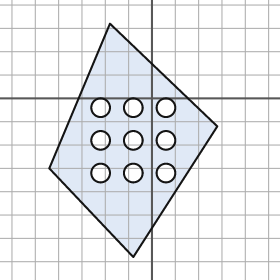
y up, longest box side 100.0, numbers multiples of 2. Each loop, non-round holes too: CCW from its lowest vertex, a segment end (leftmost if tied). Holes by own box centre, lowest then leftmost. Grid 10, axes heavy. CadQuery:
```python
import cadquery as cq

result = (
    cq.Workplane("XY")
    .moveTo(-8.0, -68.0)
    .lineTo(28.0, -12.0)
    .lineTo(-18.0, 32.0)
    .lineTo(-44.0, -30.0)
    .close()
    .moveTo(-22.0, -32.0)
    .circle(4.0)
    .moveTo(-8.0, -32.0)
    .circle(4.0)
    .moveTo(6.0, -32.0)
    .circle(4.0)
    .moveTo(-22.0, -18.0)
    .circle(4.0)
    .moveTo(-8.0, -18.0)
    .circle(4.0)
    .moveTo(6.0, -18.0)
    .circle(4.0)
    .moveTo(-22.0, -4.0)
    .circle(4.0)
    .moveTo(-8.0, -4.0)
    .circle(4.0)
    .moveTo(6.0, -4.0)
    .circle(4.0)
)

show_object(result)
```